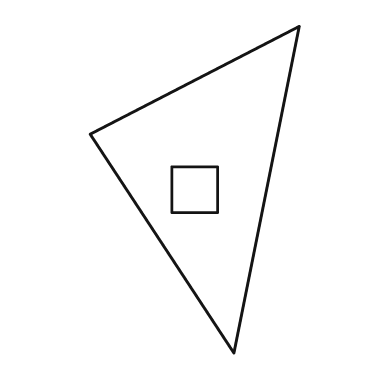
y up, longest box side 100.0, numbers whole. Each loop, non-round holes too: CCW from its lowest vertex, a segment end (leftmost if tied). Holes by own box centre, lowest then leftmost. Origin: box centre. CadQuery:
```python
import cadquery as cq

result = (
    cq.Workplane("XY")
    .moveTo(12.0, -50.0)
    .lineTo(32.0, 50.0)
    .lineTo(-32.0, 17.0)
    .close()
    .moveTo(-7.0, -7.0)
    .lineTo(7.0, -7.0)
    .lineTo(7.0, 7.0)
    .lineTo(-7.0, 7.0)
    .close()
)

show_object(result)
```